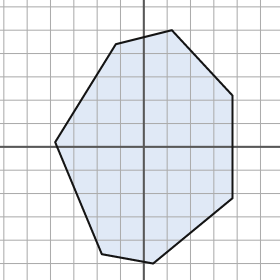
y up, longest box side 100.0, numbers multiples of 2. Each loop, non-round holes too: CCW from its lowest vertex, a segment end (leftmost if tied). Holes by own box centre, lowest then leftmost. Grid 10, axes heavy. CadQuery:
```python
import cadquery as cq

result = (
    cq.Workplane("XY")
    .moveTo(4.0, -50.0)
    .lineTo(38.0, -22.0)
    .lineTo(38.0, 22.0)
    .lineTo(12.0, 50.0)
    .lineTo(-12.0, 44.0)
    .lineTo(-38.0, 2.0)
    .lineTo(-18.0, -46.0)
    .close()
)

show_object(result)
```